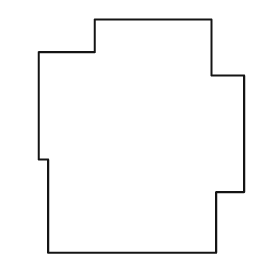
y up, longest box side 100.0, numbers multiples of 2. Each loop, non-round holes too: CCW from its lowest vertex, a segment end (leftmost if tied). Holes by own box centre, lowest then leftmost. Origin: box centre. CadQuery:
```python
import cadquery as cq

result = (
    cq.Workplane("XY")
    .moveTo(-40.0, -50.0)
    .lineTo(32.0, -50.0)
    .lineTo(32.0, -24.0)
    .lineTo(44.0, -24.0)
    .lineTo(44.0, 26.0)
    .lineTo(30.0, 26.0)
    .lineTo(30.0, 50.0)
    .lineTo(-20.0, 50.0)
    .lineTo(-20.0, 36.0)
    .lineTo(-44.0, 36.0)
    .lineTo(-44.0, -10.0)
    .lineTo(-40.0, -10.0)
    .close()
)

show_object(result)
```